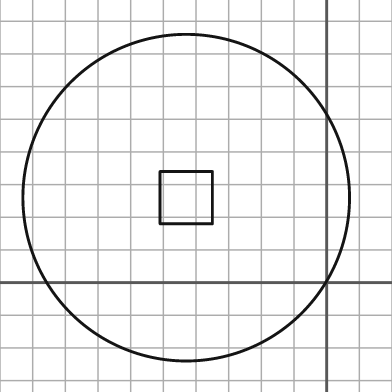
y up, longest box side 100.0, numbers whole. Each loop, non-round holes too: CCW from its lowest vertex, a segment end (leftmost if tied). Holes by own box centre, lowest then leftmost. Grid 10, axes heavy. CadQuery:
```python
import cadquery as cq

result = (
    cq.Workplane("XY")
    .moveTo(-43.0, 26.0)
    .circle(50.0)
    .moveTo(-51.0, 18.0)
    .lineTo(-35.0, 18.0)
    .lineTo(-35.0, 34.0)
    .lineTo(-51.0, 34.0)
    .close()
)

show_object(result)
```